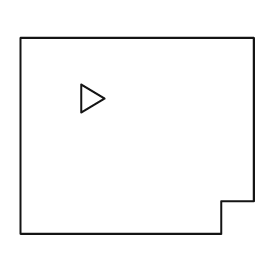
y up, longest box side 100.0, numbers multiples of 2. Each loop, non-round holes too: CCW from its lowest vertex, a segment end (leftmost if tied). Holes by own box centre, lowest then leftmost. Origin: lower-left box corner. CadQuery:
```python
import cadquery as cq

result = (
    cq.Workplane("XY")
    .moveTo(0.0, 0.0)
    .lineTo(86.0, 0.0)
    .lineTo(86.0, 14.0)
    .lineTo(100.0, 14.0)
    .lineTo(100.0, 84.0)
    .lineTo(0.0, 84.0)
    .close()
    .moveTo(26.0, 52.0)
    .lineTo(36.0, 58.0)
    .lineTo(26.0, 64.0)
    .close()
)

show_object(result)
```